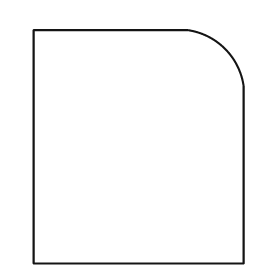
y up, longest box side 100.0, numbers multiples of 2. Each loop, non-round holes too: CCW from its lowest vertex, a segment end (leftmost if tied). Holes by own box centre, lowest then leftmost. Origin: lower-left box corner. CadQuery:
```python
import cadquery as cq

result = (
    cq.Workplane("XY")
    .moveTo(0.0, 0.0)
    .lineTo(90.0, 0.0)
    .lineTo(90.0, 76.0)
    .threePointArc((82.0, 92.0), (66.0, 100.0))
    .lineTo(0.0, 100.0)
    .close()
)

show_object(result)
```